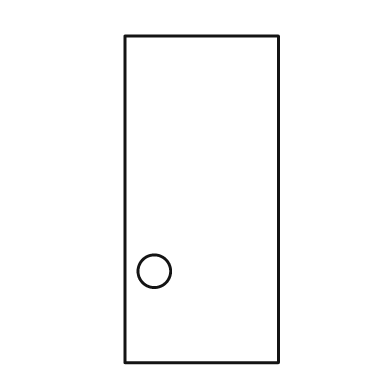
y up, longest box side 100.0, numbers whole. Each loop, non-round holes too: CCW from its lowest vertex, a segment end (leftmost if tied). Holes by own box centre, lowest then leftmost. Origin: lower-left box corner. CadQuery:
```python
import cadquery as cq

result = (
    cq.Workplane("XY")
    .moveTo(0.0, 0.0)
    .lineTo(47.0, 0.0)
    .lineTo(47.0, 100.0)
    .lineTo(0.0, 100.0)
    .close()
    .moveTo(9.0, 28.0)
    .circle(5.0)
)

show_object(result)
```